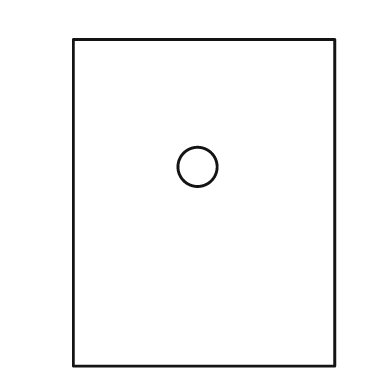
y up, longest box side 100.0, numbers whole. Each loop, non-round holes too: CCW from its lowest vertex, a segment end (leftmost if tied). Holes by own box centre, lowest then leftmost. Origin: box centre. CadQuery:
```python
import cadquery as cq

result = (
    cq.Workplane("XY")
    .moveTo(-40.0, -50.0)
    .lineTo(40.0, -50.0)
    .lineTo(40.0, 50.0)
    .lineTo(-40.0, 50.0)
    .close()
    .moveTo(-2.0, 11.0)
    .circle(6.0)
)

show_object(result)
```